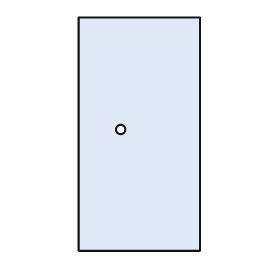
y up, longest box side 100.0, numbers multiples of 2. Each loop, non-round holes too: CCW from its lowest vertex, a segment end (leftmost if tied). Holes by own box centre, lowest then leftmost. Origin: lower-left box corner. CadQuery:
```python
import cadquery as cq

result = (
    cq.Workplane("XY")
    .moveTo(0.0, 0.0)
    .lineTo(52.0, 0.0)
    .lineTo(52.0, 100.0)
    .lineTo(0.0, 100.0)
    .close()
    .moveTo(18.0, 52.0)
    .circle(2.0)
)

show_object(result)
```